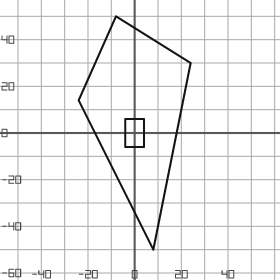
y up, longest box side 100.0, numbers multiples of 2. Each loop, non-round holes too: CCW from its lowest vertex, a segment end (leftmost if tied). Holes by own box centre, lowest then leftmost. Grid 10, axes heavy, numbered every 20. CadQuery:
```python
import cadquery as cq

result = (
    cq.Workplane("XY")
    .moveTo(8.0, -50.0)
    .lineTo(24.0, 30.0)
    .lineTo(-8.0, 50.0)
    .lineTo(-24.0, 14.0)
    .close()
    .moveTo(-4.0, -6.0)
    .lineTo(4.0, -6.0)
    .lineTo(4.0, 6.0)
    .lineTo(-4.0, 6.0)
    .close()
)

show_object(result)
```